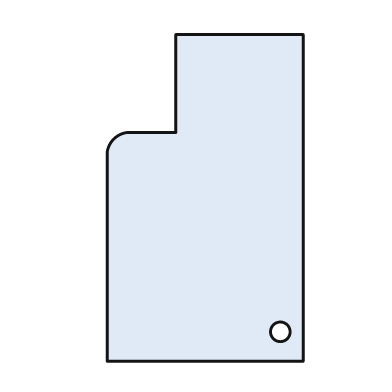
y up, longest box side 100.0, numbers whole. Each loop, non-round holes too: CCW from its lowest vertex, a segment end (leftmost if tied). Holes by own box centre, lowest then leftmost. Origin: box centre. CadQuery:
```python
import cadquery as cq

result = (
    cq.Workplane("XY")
    .moveTo(-30.0, -50.0)
    .lineTo(30.0, -50.0)
    .lineTo(30.0, 50.0)
    .lineTo(-9.0, 50.0)
    .lineTo(-9.0, 20.0)
    .lineTo(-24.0, 20.0)
    .threePointArc((-28.0, 18.0), (-30.0, 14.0))
    .close()
    .moveTo(23.0, -41.0)
    .circle(3.0)
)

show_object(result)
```